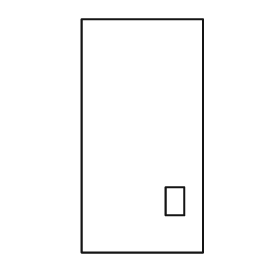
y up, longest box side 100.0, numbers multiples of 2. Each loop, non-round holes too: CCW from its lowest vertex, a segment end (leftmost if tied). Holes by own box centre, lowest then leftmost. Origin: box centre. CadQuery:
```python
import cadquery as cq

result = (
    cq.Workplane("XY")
    .moveTo(-26.0, -50.0)
    .lineTo(26.0, -50.0)
    .lineTo(26.0, 50.0)
    .lineTo(-26.0, 50.0)
    .close()
    .moveTo(10.0, -34.0)
    .lineTo(18.0, -34.0)
    .lineTo(18.0, -22.0)
    .lineTo(10.0, -22.0)
    .close()
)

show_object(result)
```